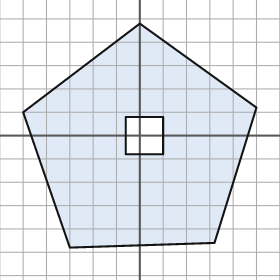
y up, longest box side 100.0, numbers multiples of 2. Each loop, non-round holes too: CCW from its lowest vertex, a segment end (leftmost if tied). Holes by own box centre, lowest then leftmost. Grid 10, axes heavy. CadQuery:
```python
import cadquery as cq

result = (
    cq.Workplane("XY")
    .moveTo(-30.0, -48.0)
    .lineTo(32.0, -46.0)
    .lineTo(50.0, 12.0)
    .lineTo(0.0, 48.0)
    .lineTo(-50.0, 10.0)
    .close()
    .moveTo(-6.0, -8.0)
    .lineTo(10.0, -8.0)
    .lineTo(10.0, 8.0)
    .lineTo(-6.0, 8.0)
    .close()
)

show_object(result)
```